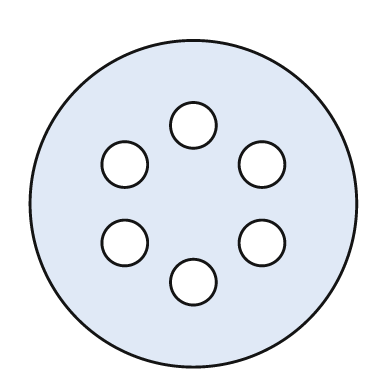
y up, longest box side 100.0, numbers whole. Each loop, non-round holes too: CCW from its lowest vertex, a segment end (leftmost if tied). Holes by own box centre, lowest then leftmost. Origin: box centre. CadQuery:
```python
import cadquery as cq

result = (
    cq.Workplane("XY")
    .moveTo(0.0, 0.0)
    .circle(50.0)
    .moveTo(0.0, -24.0)
    .circle(7.0)
    .moveTo(-21.0, -12.0)
    .circle(7.0)
    .moveTo(21.0, -12.0)
    .circle(7.0)
    .moveTo(-21.0, 12.0)
    .circle(7.0)
    .moveTo(21.0, 12.0)
    .circle(7.0)
    .moveTo(0.0, 24.0)
    .circle(7.0)
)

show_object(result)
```